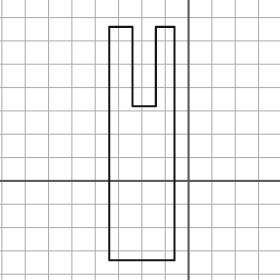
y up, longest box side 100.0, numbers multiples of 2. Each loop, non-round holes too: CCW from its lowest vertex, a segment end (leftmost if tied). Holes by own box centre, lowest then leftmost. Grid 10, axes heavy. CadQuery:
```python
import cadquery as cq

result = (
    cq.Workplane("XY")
    .moveTo(-34.0, -34.0)
    .lineTo(-6.0, -34.0)
    .lineTo(-6.0, 66.0)
    .lineTo(-14.0, 66.0)
    .lineTo(-14.0, 32.0)
    .lineTo(-24.0, 32.0)
    .lineTo(-24.0, 66.0)
    .lineTo(-34.0, 66.0)
    .close()
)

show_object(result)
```